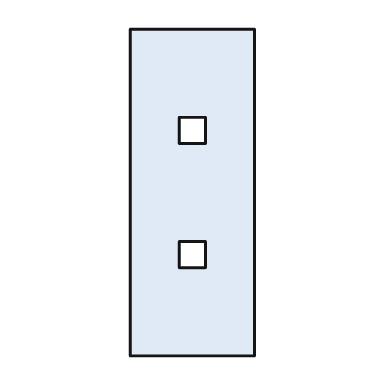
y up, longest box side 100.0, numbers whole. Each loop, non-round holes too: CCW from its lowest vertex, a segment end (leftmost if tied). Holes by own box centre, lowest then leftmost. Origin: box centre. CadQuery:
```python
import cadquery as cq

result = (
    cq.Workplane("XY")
    .moveTo(-19.0, -50.0)
    .lineTo(19.0, -50.0)
    .lineTo(19.0, 50.0)
    .lineTo(-19.0, 50.0)
    .close()
    .moveTo(-4.0, -23.0)
    .lineTo(4.0, -23.0)
    .lineTo(4.0, -15.0)
    .lineTo(-4.0, -15.0)
    .close()
    .moveTo(-4.0, 15.0)
    .lineTo(4.0, 15.0)
    .lineTo(4.0, 23.0)
    .lineTo(-4.0, 23.0)
    .close()
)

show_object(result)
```